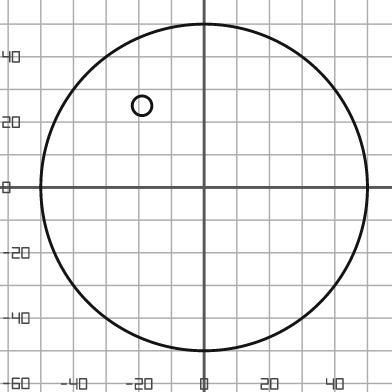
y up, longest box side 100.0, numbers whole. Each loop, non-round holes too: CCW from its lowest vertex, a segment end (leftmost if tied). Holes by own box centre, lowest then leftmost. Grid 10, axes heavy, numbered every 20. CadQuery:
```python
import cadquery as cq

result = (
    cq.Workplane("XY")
    .moveTo(0.0, 0.0)
    .circle(50.0)
    .moveTo(-19.0, 25.0)
    .circle(3.0)
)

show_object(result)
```